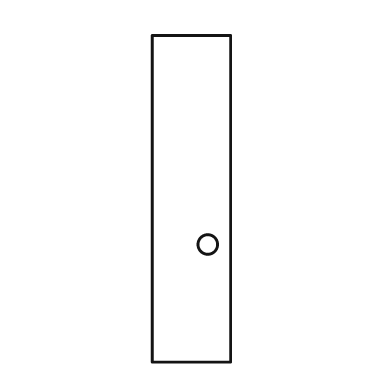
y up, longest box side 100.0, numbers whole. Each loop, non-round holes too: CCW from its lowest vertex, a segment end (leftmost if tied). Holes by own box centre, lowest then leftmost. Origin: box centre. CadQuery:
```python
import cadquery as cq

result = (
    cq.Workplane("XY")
    .moveTo(-12.0, -50.0)
    .lineTo(12.0, -50.0)
    .lineTo(12.0, 50.0)
    .lineTo(-12.0, 50.0)
    .close()
    .moveTo(5.0, -14.0)
    .circle(3.0)
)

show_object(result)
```